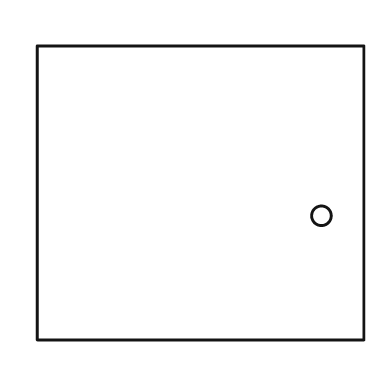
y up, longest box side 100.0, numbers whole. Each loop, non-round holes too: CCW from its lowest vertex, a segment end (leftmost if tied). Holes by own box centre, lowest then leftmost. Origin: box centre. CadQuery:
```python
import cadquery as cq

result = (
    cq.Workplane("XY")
    .moveTo(-50.0, -45.0)
    .lineTo(50.0, -45.0)
    .lineTo(50.0, 45.0)
    .lineTo(-50.0, 45.0)
    .close()
    .moveTo(37.0, -7.0)
    .circle(3.0)
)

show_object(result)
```